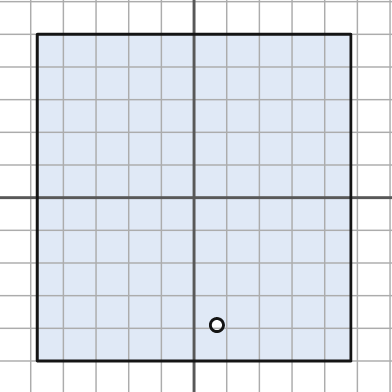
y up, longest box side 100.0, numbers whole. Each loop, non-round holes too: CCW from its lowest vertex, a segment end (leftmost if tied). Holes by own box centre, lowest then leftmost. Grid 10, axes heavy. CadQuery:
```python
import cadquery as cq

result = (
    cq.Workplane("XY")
    .moveTo(-48.0, -50.0)
    .lineTo(48.0, -50.0)
    .lineTo(48.0, 50.0)
    .lineTo(-48.0, 50.0)
    .close()
    .moveTo(7.0, -39.0)
    .circle(2.0)
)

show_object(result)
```